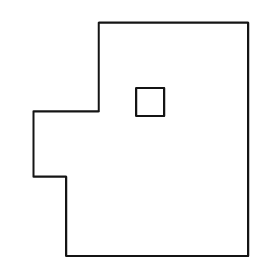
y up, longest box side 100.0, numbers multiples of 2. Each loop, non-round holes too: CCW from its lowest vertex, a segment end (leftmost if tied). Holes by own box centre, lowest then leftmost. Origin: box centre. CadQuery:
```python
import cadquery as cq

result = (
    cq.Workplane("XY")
    .moveTo(-32.0, -50.0)
    .lineTo(46.0, -50.0)
    .lineTo(46.0, 50.0)
    .lineTo(-18.0, 50.0)
    .lineTo(-18.0, 12.0)
    .lineTo(-46.0, 12.0)
    .lineTo(-46.0, -16.0)
    .lineTo(-32.0, -16.0)
    .close()
    .moveTo(-2.0, 10.0)
    .lineTo(10.0, 10.0)
    .lineTo(10.0, 22.0)
    .lineTo(-2.0, 22.0)
    .close()
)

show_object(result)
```